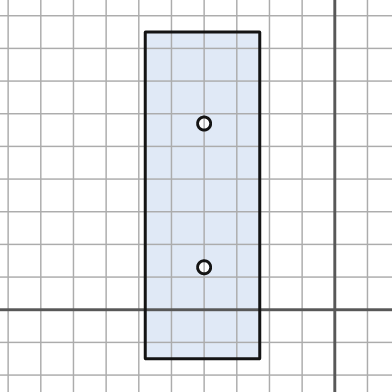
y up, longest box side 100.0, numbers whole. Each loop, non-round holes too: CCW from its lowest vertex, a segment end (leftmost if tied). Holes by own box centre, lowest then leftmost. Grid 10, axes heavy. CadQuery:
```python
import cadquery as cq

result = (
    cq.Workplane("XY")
    .moveTo(-58.0, -15.0)
    .lineTo(-23.0, -15.0)
    .lineTo(-23.0, 85.0)
    .lineTo(-58.0, 85.0)
    .close()
    .moveTo(-40.0, 13.0)
    .circle(2.0)
    .moveTo(-40.0, 57.0)
    .circle(2.0)
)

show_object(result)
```